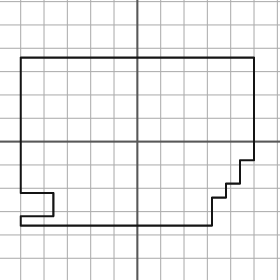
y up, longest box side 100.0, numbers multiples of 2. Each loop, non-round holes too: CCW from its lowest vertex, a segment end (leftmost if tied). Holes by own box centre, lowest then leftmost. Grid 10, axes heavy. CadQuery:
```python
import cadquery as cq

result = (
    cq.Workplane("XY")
    .moveTo(-50.0, -36.0)
    .lineTo(32.0, -36.0)
    .lineTo(32.0, -24.0)
    .lineTo(38.0, -24.0)
    .lineTo(38.0, -18.0)
    .lineTo(44.0, -18.0)
    .lineTo(44.0, -8.0)
    .lineTo(50.0, -8.0)
    .lineTo(50.0, 36.0)
    .lineTo(-50.0, 36.0)
    .lineTo(-50.0, -22.0)
    .lineTo(-36.0, -22.0)
    .lineTo(-36.0, -32.0)
    .lineTo(-50.0, -32.0)
    .close()
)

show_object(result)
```